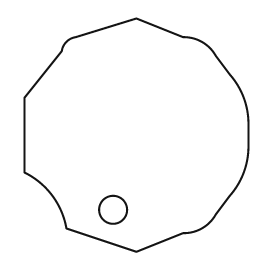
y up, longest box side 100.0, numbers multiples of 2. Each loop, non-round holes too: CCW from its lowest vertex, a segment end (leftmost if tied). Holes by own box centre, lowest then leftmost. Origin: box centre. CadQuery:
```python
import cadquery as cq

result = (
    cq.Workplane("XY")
    .moveTo(0.0, -50.0)
    .lineTo(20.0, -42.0)
    .threePointArc((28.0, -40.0), (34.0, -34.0))
    .lineTo(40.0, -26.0)
    .threePointArc((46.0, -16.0), (48.0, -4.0))
    .lineTo(48.0, 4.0)
    .threePointArc((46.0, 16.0), (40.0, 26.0))
    .lineTo(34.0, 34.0)
    .threePointArc((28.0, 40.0), (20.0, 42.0))
    .lineTo(0.0, 50.0)
    .lineTo(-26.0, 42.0)
    .threePointArc((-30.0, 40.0), (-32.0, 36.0))
    .lineTo(-48.0, 16.0)
    .lineTo(-48.0, -16.0)
    .threePointArc((-36.0, -26.0), (-30.0, -40.0))
    .close()
    .moveTo(-10.0, -32.0)
    .circle(6.0)
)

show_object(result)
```